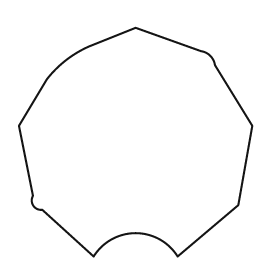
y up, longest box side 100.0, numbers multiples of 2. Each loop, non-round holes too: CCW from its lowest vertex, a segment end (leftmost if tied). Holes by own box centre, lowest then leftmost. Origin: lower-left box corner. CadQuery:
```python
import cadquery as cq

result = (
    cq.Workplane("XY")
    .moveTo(32.0, 0.0)
    .threePointArc((50.0, 10.0), (68.0, 0.0))
    .lineTo(94.0, 22.0)
    .lineTo(100.0, 56.0)
    .lineTo(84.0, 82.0)
    .threePointArc((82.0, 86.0), (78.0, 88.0))
    .lineTo(50.0, 98.0)
    .lineTo(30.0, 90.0)
    .threePointArc((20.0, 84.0), (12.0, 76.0))
    .lineTo(0.0, 56.0)
    .lineTo(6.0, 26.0)
    .threePointArc((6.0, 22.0), (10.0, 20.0))
    .close()
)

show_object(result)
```